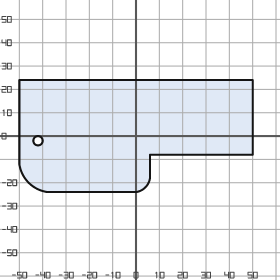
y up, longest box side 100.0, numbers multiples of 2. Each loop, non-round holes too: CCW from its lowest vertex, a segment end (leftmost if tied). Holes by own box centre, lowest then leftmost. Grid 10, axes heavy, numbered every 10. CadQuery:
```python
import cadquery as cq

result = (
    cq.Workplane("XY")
    .moveTo(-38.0, -24.0)
    .lineTo(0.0, -24.0)
    .threePointArc((4.0, -22.0), (6.0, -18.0))
    .lineTo(6.0, -8.0)
    .lineTo(50.0, -8.0)
    .lineTo(50.0, 24.0)
    .lineTo(-50.0, 24.0)
    .lineTo(-50.0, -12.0)
    .threePointArc((-46.0, -20.0), (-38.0, -24.0))
    .close()
    .moveTo(-42.0, -2.0)
    .circle(2.0)
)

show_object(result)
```